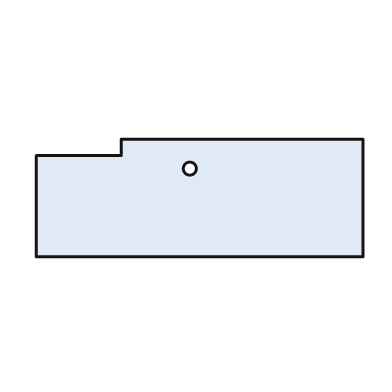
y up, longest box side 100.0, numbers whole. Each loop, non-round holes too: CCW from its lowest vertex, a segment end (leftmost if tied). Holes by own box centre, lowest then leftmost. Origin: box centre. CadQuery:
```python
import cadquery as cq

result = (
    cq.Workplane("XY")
    .moveTo(-50.0, -18.0)
    .lineTo(50.0, -18.0)
    .lineTo(50.0, 18.0)
    .lineTo(-24.0, 18.0)
    .lineTo(-24.0, 13.0)
    .lineTo(-50.0, 13.0)
    .close()
    .moveTo(-3.0, 9.0)
    .circle(2.0)
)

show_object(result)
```